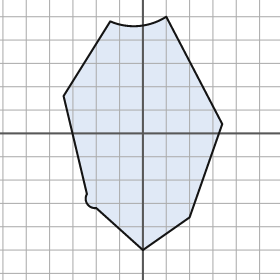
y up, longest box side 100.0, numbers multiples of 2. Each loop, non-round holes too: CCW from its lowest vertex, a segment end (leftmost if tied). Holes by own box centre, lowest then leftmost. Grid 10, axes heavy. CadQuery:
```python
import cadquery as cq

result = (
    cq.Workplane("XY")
    .moveTo(0.0, -50.0)
    .lineTo(20.0, -36.0)
    .lineTo(34.0, 4.0)
    .lineTo(10.0, 50.0)
    .threePointArc((-2.0, 46.0), (-14.0, 48.0))
    .lineTo(-34.0, 16.0)
    .lineTo(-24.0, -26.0)
    .threePointArc((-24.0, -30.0), (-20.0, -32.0))
    .close()
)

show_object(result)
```